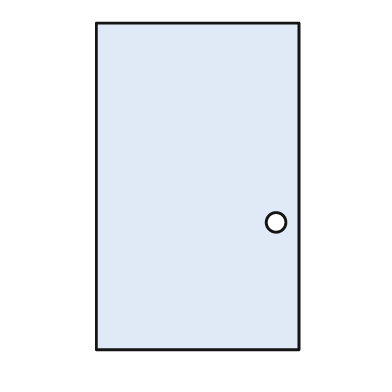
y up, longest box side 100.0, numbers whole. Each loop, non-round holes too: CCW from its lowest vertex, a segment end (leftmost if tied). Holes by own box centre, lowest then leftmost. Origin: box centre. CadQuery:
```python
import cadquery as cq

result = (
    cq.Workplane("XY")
    .moveTo(-31.0, -50.0)
    .lineTo(31.0, -50.0)
    .lineTo(31.0, 50.0)
    .lineTo(-31.0, 50.0)
    .close()
    .moveTo(24.0, -11.0)
    .circle(3.0)
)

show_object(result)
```